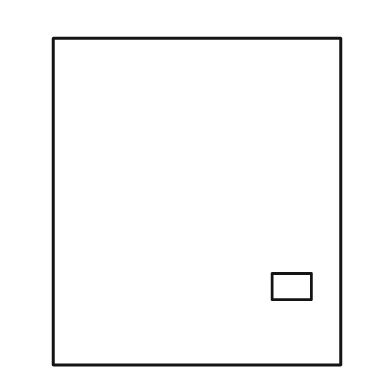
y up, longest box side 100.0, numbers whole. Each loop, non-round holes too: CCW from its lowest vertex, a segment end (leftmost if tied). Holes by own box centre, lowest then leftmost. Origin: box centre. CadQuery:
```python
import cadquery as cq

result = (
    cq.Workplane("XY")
    .moveTo(-44.0, -50.0)
    .lineTo(44.0, -50.0)
    .lineTo(44.0, 50.0)
    .lineTo(-44.0, 50.0)
    .close()
    .moveTo(23.0, -30.0)
    .lineTo(35.0, -30.0)
    .lineTo(35.0, -22.0)
    .lineTo(23.0, -22.0)
    .close()
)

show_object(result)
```